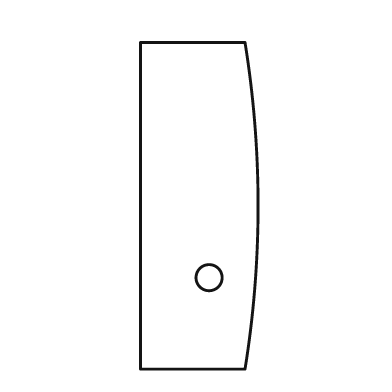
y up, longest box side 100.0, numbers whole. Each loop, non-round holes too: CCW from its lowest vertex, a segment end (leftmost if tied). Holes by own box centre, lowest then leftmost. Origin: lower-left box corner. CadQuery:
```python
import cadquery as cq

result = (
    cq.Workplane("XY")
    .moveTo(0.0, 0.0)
    .lineTo(32.0, 0.0)
    .threePointArc((36.0, 50.0), (32.0, 100.0))
    .lineTo(0.0, 100.0)
    .close()
    .moveTo(21.0, 28.0)
    .circle(4.0)
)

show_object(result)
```